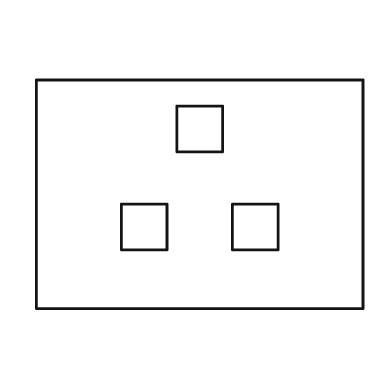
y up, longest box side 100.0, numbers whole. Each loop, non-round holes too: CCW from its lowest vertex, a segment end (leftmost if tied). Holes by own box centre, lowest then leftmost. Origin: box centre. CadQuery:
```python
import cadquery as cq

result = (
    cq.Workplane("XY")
    .moveTo(-50.0, -35.0)
    .lineTo(50.0, -35.0)
    .lineTo(50.0, 35.0)
    .lineTo(-50.0, 35.0)
    .close()
    .moveTo(-24.0, -17.0)
    .lineTo(-10.0, -17.0)
    .lineTo(-10.0, -3.0)
    .lineTo(-24.0, -3.0)
    .close()
    .moveTo(10.0, -17.0)
    .lineTo(24.0, -17.0)
    .lineTo(24.0, -3.0)
    .lineTo(10.0, -3.0)
    .close()
    .moveTo(-7.0, 13.0)
    .lineTo(7.0, 13.0)
    .lineTo(7.0, 27.0)
    .lineTo(-7.0, 27.0)
    .close()
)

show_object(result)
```